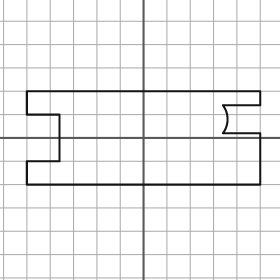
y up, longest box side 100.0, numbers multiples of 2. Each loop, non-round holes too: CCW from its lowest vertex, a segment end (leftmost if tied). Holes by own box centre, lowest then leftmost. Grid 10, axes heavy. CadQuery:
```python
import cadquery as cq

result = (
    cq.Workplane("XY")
    .moveTo(-50.0, -20.0)
    .lineTo(50.0, -20.0)
    .lineTo(50.0, 2.0)
    .lineTo(34.0, 2.0)
    .threePointArc((36.0, 8.0), (34.0, 14.0))
    .lineTo(50.0, 14.0)
    .lineTo(50.0, 20.0)
    .lineTo(-50.0, 20.0)
    .lineTo(-50.0, 10.0)
    .lineTo(-36.0, 10.0)
    .lineTo(-36.0, -10.0)
    .lineTo(-50.0, -10.0)
    .close()
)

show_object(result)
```